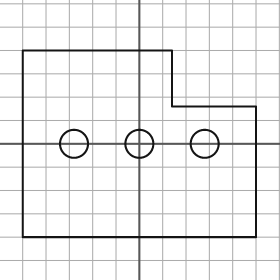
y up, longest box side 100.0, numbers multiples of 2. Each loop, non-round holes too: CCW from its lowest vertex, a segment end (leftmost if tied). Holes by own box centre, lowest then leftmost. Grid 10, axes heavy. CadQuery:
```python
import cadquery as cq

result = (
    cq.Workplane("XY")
    .moveTo(-50.0, -40.0)
    .lineTo(50.0, -40.0)
    .lineTo(50.0, 16.0)
    .lineTo(14.0, 16.0)
    .lineTo(14.0, 40.0)
    .lineTo(-50.0, 40.0)
    .close()
    .moveTo(-28.0, 0.0)
    .circle(6.0)
    .moveTo(0.0, 0.0)
    .circle(6.0)
    .moveTo(28.0, 0.0)
    .circle(6.0)
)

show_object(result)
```